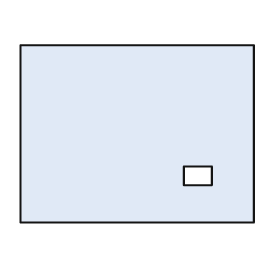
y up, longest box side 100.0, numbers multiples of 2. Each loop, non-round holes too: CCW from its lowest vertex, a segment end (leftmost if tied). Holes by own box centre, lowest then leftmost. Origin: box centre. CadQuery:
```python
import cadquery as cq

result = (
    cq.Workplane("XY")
    .moveTo(-50.0, -38.0)
    .lineTo(50.0, -38.0)
    .lineTo(50.0, 38.0)
    .lineTo(-50.0, 38.0)
    .close()
    .moveTo(20.0, -22.0)
    .lineTo(32.0, -22.0)
    .lineTo(32.0, -14.0)
    .lineTo(20.0, -14.0)
    .close()
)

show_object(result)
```